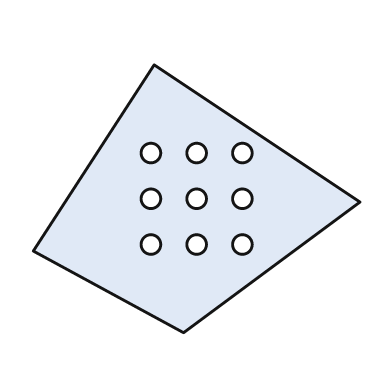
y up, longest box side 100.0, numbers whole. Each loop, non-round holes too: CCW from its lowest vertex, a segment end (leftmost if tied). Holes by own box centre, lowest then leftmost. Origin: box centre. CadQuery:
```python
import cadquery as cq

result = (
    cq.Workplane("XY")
    .moveTo(-4.0, -41.0)
    .lineTo(50.0, -1.0)
    .lineTo(-13.0, 41.0)
    .lineTo(-50.0, -16.0)
    .close()
    .moveTo(-14.0, -14.0)
    .circle(3.0)
    .moveTo(0.0, -14.0)
    .circle(3.0)
    .moveTo(14.0, -14.0)
    .circle(3.0)
    .moveTo(-14.0, 0.0)
    .circle(3.0)
    .moveTo(0.0, 0.0)
    .circle(3.0)
    .moveTo(14.0, 0.0)
    .circle(3.0)
    .moveTo(-14.0, 14.0)
    .circle(3.0)
    .moveTo(0.0, 14.0)
    .circle(3.0)
    .moveTo(14.0, 14.0)
    .circle(3.0)
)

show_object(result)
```